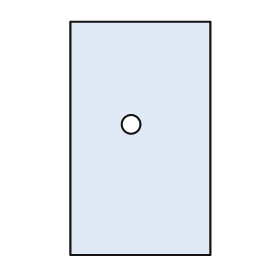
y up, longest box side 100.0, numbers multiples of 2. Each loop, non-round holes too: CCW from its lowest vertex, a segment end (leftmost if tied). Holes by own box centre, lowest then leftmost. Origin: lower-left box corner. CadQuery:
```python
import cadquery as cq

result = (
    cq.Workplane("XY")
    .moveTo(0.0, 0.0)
    .lineTo(60.0, 0.0)
    .lineTo(60.0, 100.0)
    .lineTo(0.0, 100.0)
    .close()
    .moveTo(26.0, 56.0)
    .circle(4.0)
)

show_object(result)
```